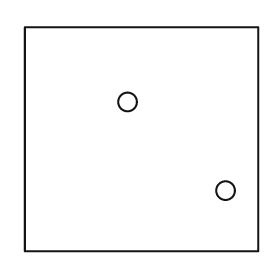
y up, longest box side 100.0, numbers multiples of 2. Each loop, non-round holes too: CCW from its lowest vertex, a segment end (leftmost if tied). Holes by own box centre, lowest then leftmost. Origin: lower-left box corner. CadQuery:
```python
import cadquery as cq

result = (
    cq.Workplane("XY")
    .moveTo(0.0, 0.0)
    .lineTo(100.0, 0.0)
    .lineTo(100.0, 96.0)
    .lineTo(0.0, 96.0)
    .close()
    .moveTo(86.0, 26.0)
    .circle(4.0)
    .moveTo(44.0, 64.0)
    .circle(4.0)
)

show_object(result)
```